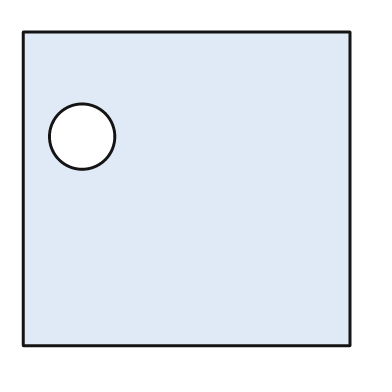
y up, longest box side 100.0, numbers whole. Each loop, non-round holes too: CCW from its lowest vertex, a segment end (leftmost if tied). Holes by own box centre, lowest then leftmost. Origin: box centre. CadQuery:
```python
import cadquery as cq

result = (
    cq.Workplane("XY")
    .moveTo(-50.0, -48.0)
    .lineTo(50.0, -48.0)
    .lineTo(50.0, 48.0)
    .lineTo(-50.0, 48.0)
    .close()
    .moveTo(-32.0, 16.0)
    .circle(10.0)
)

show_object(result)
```